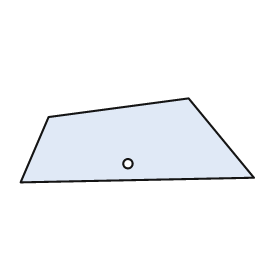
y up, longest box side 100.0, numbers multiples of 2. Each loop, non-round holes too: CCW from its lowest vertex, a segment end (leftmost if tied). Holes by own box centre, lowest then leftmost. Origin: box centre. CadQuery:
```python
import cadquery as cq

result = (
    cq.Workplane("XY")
    .moveTo(-50.0, -18.0)
    .lineTo(50.0, -16.0)
    .lineTo(22.0, 18.0)
    .lineTo(-38.0, 10.0)
    .close()
    .moveTo(-4.0, -10.0)
    .circle(2.0)
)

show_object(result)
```